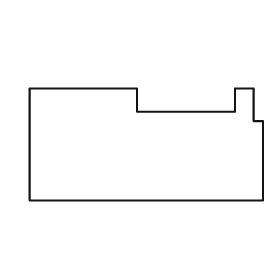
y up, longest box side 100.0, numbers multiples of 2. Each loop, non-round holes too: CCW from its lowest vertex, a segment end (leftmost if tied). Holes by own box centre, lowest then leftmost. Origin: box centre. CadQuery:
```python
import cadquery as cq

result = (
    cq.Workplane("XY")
    .moveTo(-50.0, -24.0)
    .lineTo(50.0, -24.0)
    .lineTo(50.0, 10.0)
    .lineTo(46.0, 10.0)
    .lineTo(46.0, 24.0)
    .lineTo(38.0, 24.0)
    .lineTo(38.0, 14.0)
    .lineTo(-4.0, 14.0)
    .lineTo(-4.0, 24.0)
    .lineTo(-50.0, 24.0)
    .close()
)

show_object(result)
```